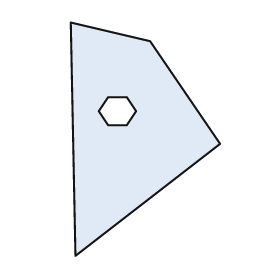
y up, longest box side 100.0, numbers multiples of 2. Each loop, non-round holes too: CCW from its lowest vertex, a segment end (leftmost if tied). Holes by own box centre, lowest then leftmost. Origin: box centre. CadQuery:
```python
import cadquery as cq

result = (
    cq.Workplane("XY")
    .moveTo(-30.0, -50.0)
    .lineTo(32.0, -2.0)
    .lineTo(2.0, 42.0)
    .lineTo(-32.0, 50.0)
    .close()
    .moveTo(-16.0, 6.0)
    .lineTo(-8.0, 6.0)
    .lineTo(-4.0, 12.0)
    .lineTo(-8.0, 18.0)
    .lineTo(-16.0, 18.0)
    .lineTo(-20.0, 12.0)
    .close()
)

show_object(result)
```